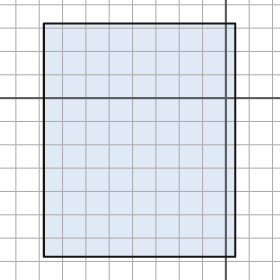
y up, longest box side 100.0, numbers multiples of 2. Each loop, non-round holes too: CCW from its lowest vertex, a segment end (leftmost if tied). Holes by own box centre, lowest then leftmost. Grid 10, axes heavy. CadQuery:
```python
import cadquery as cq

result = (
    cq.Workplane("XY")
    .moveTo(-78.0, -68.0)
    .lineTo(4.0, -68.0)
    .lineTo(4.0, 32.0)
    .lineTo(-78.0, 32.0)
    .close()
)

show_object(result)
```